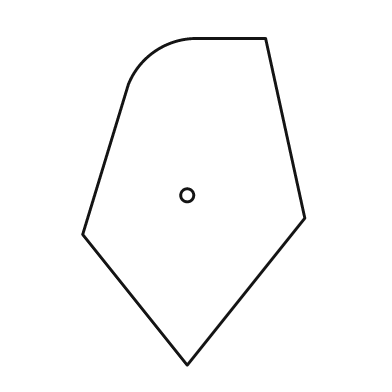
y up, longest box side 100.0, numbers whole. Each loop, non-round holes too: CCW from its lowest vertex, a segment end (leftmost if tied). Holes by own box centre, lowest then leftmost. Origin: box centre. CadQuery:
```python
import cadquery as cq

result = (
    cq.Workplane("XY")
    .moveTo(-2.0, -50.0)
    .lineTo(34.0, -5.0)
    .lineTo(22.0, 50.0)
    .lineTo(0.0, 50.0)
    .threePointArc((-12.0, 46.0), (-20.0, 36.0))
    .lineTo(-34.0, -10.0)
    .close()
    .moveTo(-2.0, 2.0)
    .circle(2.0)
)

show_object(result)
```